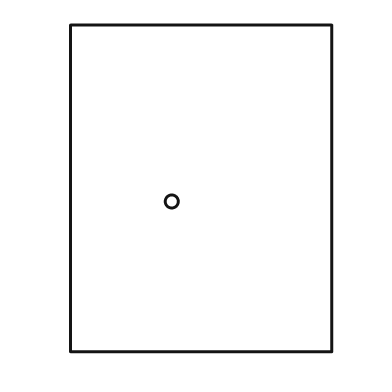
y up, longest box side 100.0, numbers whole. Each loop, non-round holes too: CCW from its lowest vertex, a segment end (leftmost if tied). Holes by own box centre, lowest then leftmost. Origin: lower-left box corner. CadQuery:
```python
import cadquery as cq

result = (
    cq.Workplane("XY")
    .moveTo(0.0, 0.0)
    .lineTo(80.0, 0.0)
    .lineTo(80.0, 100.0)
    .lineTo(0.0, 100.0)
    .close()
    .moveTo(31.0, 46.0)
    .circle(2.0)
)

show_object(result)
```